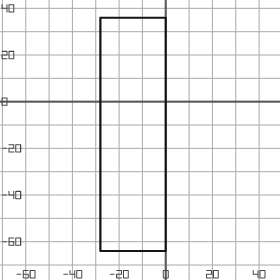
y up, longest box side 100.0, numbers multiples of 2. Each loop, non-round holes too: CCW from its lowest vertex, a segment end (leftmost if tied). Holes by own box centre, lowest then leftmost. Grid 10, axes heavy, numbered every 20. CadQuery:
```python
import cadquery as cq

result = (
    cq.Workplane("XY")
    .moveTo(-28.0, -64.0)
    .lineTo(0.0, -64.0)
    .lineTo(0.0, 36.0)
    .lineTo(-28.0, 36.0)
    .close()
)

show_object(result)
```